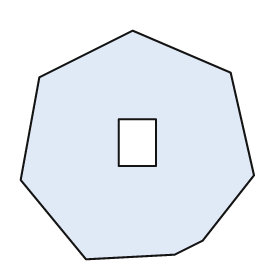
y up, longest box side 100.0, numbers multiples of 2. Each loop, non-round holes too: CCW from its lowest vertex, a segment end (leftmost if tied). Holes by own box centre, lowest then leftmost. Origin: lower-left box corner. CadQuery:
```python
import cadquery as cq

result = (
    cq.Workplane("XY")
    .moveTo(28.0, 0.0)
    .lineTo(66.0, 2.0)
    .lineTo(78.0, 8.0)
    .lineTo(100.0, 36.0)
    .lineTo(90.0, 80.0)
    .lineTo(48.0, 98.0)
    .lineTo(8.0, 78.0)
    .lineTo(0.0, 34.0)
    .close()
    .moveTo(42.0, 40.0)
    .lineTo(58.0, 40.0)
    .lineTo(58.0, 60.0)
    .lineTo(42.0, 60.0)
    .close()
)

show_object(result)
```